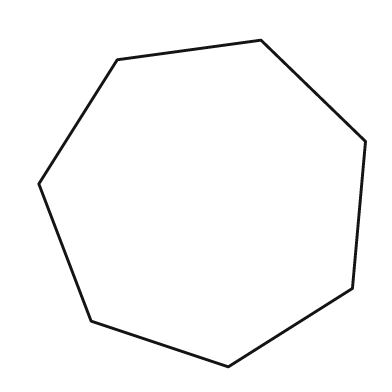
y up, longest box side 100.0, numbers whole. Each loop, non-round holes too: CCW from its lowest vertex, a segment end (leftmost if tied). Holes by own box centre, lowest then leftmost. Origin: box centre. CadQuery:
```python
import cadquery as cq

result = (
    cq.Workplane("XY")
    .moveTo(8.0, -50.0)
    .lineTo(46.0, -26.0)
    .lineTo(50.0, 19.0)
    .lineTo(18.0, 50.0)
    .lineTo(-26.0, 44.0)
    .lineTo(-50.0, 6.0)
    .lineTo(-34.0, -36.0)
    .close()
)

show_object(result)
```